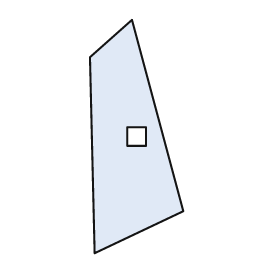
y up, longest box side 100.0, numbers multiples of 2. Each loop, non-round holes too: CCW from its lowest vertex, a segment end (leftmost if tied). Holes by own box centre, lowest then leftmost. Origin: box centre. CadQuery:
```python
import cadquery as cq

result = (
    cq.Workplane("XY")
    .moveTo(-18.0, -50.0)
    .lineTo(20.0, -32.0)
    .lineTo(-2.0, 50.0)
    .lineTo(-20.0, 34.0)
    .close()
    .moveTo(-4.0, -4.0)
    .lineTo(4.0, -4.0)
    .lineTo(4.0, 4.0)
    .lineTo(-4.0, 4.0)
    .close()
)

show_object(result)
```